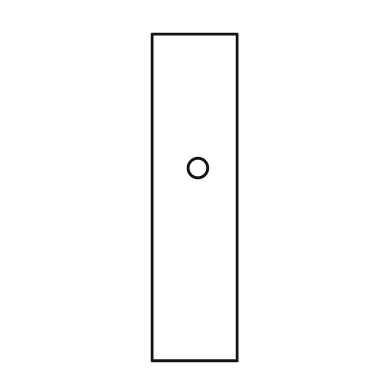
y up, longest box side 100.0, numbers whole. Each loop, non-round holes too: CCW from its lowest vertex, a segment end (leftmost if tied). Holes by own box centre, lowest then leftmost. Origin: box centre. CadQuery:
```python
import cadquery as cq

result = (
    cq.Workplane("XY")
    .moveTo(-13.0, -50.0)
    .lineTo(13.0, -50.0)
    .lineTo(13.0, 50.0)
    .lineTo(-13.0, 50.0)
    .close()
    .moveTo(1.0, 9.0)
    .circle(3.0)
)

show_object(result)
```